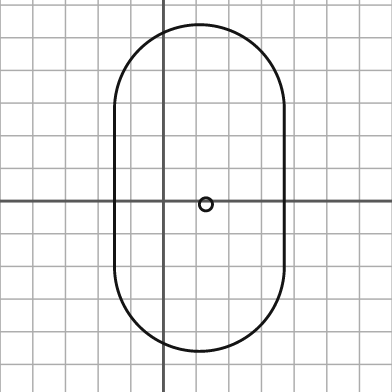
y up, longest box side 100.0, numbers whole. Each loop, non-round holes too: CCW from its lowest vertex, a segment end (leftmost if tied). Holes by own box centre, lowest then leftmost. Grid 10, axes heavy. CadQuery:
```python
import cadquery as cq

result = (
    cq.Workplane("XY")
    .moveTo(-15.0, -20.0)
    .threePointArc((11.0, -46.0), (37.0, -20.0))
    .lineTo(37.0, 28.0)
    .threePointArc((11.0, 54.0), (-15.0, 28.0))
    .close()
    .moveTo(13.0, -1.0)
    .circle(2.0)
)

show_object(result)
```